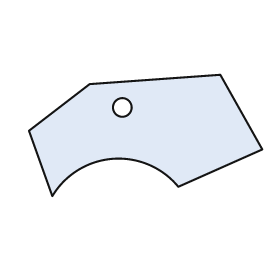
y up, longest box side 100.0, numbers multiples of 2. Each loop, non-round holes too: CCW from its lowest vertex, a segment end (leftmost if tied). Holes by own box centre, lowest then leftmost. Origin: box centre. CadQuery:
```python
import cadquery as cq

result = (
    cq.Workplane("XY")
    .moveTo(-40.0, -26.0)
    .threePointArc((-14.0, -10.0), (14.0, -22.0))
    .lineTo(50.0, -6.0)
    .lineTo(32.0, 26.0)
    .lineTo(-24.0, 22.0)
    .lineTo(-50.0, 2.0)
    .close()
    .moveTo(-10.0, 12.0)
    .circle(4.0)
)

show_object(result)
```